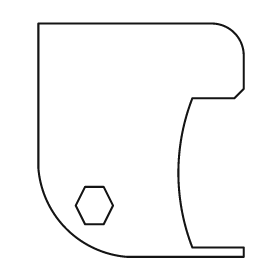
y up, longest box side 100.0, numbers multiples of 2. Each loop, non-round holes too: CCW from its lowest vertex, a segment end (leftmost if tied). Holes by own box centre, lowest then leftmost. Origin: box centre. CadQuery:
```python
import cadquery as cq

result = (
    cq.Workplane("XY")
    .moveTo(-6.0, -50.0)
    .lineTo(44.0, -50.0)
    .lineTo(44.0, -46.0)
    .lineTo(22.0, -46.0)
    .threePointArc((16.0, -14.0), (22.0, 18.0))
    .lineTo(40.0, 18.0)
    .lineTo(44.0, 22.0)
    .lineTo(44.0, 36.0)
    .threePointArc((40.0, 46.0), (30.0, 50.0))
    .lineTo(-44.0, 50.0)
    .lineTo(-44.0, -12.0)
    .threePointArc((-32.0, -38.0), (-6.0, -50.0))
    .close()
    .moveTo(-24.0, -36.0)
    .lineTo(-16.0, -36.0)
    .lineTo(-12.0, -28.0)
    .lineTo(-16.0, -20.0)
    .lineTo(-24.0, -20.0)
    .lineTo(-28.0, -28.0)
    .close()
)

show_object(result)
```